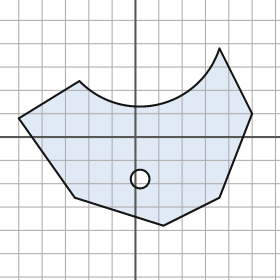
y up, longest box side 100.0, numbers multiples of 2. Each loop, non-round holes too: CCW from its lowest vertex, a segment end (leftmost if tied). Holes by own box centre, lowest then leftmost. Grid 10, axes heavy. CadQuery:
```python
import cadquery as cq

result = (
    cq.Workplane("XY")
    .moveTo(12.0, -38.0)
    .lineTo(36.0, -26.0)
    .lineTo(50.0, 10.0)
    .lineTo(36.0, 38.0)
    .threePointArc((10.0, 14.0), (-24.0, 24.0))
    .lineTo(-50.0, 8.0)
    .lineTo(-26.0, -26.0)
    .close()
    .moveTo(2.0, -18.0)
    .circle(4.0)
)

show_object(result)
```